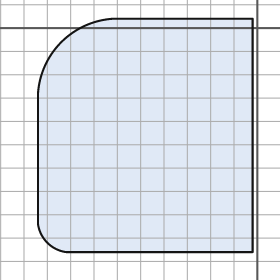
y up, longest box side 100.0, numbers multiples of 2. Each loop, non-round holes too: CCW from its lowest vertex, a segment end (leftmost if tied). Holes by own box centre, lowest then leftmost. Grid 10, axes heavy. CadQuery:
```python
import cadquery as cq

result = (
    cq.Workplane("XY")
    .moveTo(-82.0, -96.0)
    .lineTo(-2.0, -96.0)
    .lineTo(-2.0, 4.0)
    .lineTo(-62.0, 4.0)
    .threePointArc((-84.0, -6.0), (-94.0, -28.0))
    .lineTo(-94.0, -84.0)
    .threePointArc((-90.0, -92.0), (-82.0, -96.0))
    .close()
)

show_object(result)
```